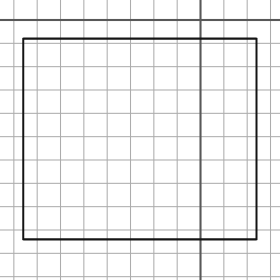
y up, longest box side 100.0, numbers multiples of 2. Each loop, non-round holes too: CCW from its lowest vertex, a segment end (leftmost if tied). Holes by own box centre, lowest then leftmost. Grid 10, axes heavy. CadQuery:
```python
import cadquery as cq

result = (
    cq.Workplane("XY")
    .moveTo(-76.0, -94.0)
    .lineTo(24.0, -94.0)
    .lineTo(24.0, -8.0)
    .lineTo(-76.0, -8.0)
    .close()
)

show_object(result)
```